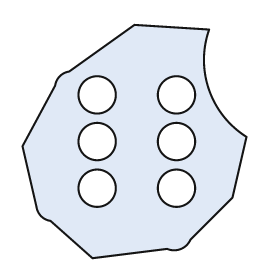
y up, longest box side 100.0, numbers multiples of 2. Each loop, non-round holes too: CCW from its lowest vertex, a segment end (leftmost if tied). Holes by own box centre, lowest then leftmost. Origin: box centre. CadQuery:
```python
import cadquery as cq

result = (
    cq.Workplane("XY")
    .moveTo(-18.0, -50.0)
    .lineTo(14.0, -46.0)
    .threePointArc((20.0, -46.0), (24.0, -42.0))
    .lineTo(42.0, -24.0)
    .lineTo(48.0, 2.0)
    .threePointArc((32.0, 22.0), (32.0, 48.0))
    .lineTo(0.0, 50.0)
    .lineTo(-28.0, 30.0)
    .threePointArc((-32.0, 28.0), (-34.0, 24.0))
    .lineTo(-48.0, -2.0)
    .lineTo(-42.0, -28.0)
    .threePointArc((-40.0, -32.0), (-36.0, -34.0))
    .close()
    .moveTo(-16.0, -20.0)
    .circle(8.0)
    .moveTo(18.0, -20.0)
    .circle(8.0)
    .moveTo(-16.0, 0.0)
    .circle(8.0)
    .moveTo(18.0, 0.0)
    .circle(8.0)
    .moveTo(-16.0, 20.0)
    .circle(8.0)
    .moveTo(18.0, 20.0)
    .circle(8.0)
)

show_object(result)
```